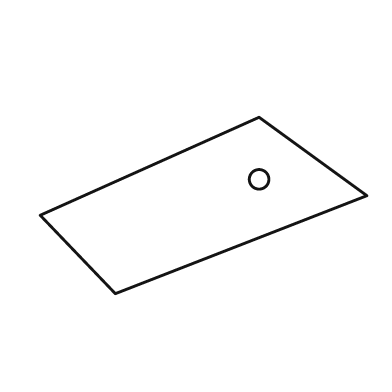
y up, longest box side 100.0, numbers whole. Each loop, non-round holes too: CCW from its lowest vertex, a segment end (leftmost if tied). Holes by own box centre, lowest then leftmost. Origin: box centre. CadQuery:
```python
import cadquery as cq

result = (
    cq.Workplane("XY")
    .moveTo(-27.0, -27.0)
    .lineTo(50.0, 3.0)
    .lineTo(17.0, 27.0)
    .lineTo(-50.0, -3.0)
    .close()
    .moveTo(17.0, 8.0)
    .circle(3.0)
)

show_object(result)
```